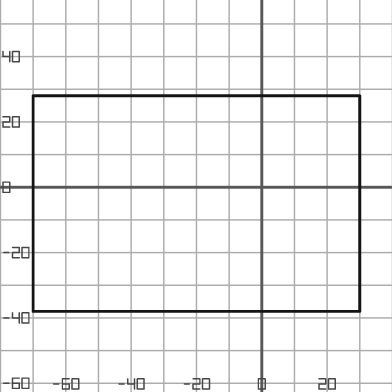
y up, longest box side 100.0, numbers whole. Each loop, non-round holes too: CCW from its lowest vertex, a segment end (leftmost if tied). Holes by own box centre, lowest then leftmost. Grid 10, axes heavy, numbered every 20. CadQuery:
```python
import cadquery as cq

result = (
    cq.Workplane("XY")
    .moveTo(-70.0, -38.0)
    .lineTo(30.0, -38.0)
    .lineTo(30.0, 28.0)
    .lineTo(-70.0, 28.0)
    .close()
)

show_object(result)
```